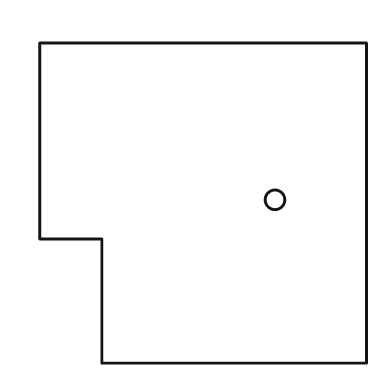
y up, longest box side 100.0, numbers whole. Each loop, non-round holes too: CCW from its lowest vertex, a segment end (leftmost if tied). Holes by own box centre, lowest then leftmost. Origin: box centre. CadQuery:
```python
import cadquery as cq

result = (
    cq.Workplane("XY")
    .moveTo(-31.0, -49.0)
    .lineTo(50.0, -49.0)
    .lineTo(50.0, 49.0)
    .lineTo(-50.0, 49.0)
    .lineTo(-50.0, -11.0)
    .lineTo(-31.0, -11.0)
    .close()
    .moveTo(22.0, 1.0)
    .circle(3.0)
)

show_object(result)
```